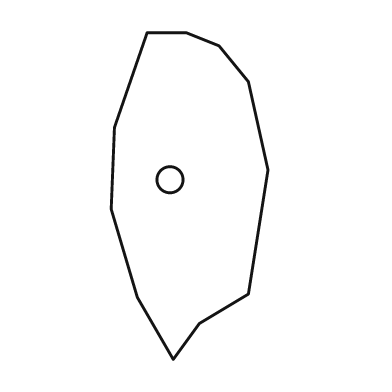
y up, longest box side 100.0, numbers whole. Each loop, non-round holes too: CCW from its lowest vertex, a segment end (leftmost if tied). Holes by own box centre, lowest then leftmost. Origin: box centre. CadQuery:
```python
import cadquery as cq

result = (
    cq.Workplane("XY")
    .moveTo(-5.0, -50.0)
    .lineTo(3.0, -39.0)
    .lineTo(18.0, -30.0)
    .lineTo(24.0, 8.0)
    .lineTo(18.0, 35.0)
    .lineTo(9.0, 46.0)
    .lineTo(-1.0, 50.0)
    .lineTo(-13.0, 50.0)
    .lineTo(-23.0, 21.0)
    .lineTo(-24.0, -4.0)
    .lineTo(-16.0, -31.0)
    .close()
    .moveTo(-6.0, 5.0)
    .circle(4.0)
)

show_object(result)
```